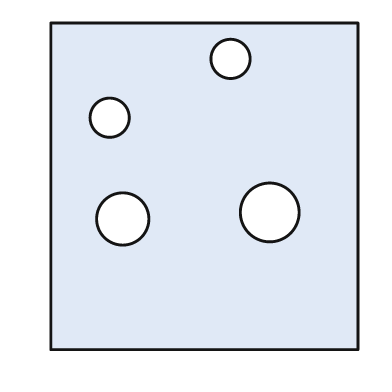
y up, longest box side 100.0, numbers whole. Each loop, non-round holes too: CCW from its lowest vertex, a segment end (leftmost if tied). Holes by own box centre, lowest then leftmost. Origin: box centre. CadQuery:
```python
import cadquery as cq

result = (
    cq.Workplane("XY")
    .moveTo(-47.0, -50.0)
    .lineTo(47.0, -50.0)
    .lineTo(47.0, 50.0)
    .lineTo(-47.0, 50.0)
    .close()
    .moveTo(-25.0, -10.0)
    .circle(8.0)
    .moveTo(20.0, -8.0)
    .circle(9.0)
    .moveTo(-29.0, 21.0)
    .circle(6.0)
    .moveTo(8.0, 39.0)
    .circle(6.0)
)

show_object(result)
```